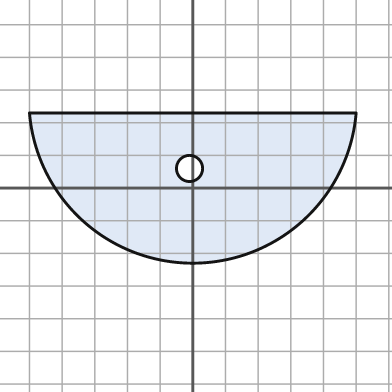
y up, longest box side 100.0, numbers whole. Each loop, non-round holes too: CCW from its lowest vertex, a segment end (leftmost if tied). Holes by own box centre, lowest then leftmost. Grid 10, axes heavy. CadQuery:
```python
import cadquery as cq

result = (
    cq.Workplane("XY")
    .moveTo(-50.0, 23.0)
    .threePointArc((0.0, -23.0), (50.0, 23.0))
    .close()
    .moveTo(-1.0, 6.0)
    .circle(4.0)
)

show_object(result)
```